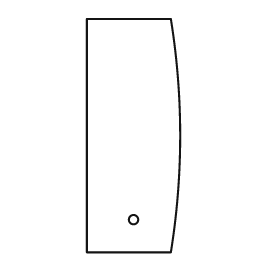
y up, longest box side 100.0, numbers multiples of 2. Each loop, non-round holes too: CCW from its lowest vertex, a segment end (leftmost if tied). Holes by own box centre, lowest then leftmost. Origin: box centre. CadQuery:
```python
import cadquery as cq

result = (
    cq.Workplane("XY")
    .moveTo(-20.0, -50.0)
    .lineTo(16.0, -50.0)
    .threePointArc((20.0, 0.0), (16.0, 50.0))
    .lineTo(-20.0, 50.0)
    .close()
    .moveTo(0.0, -36.0)
    .circle(2.0)
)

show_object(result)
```